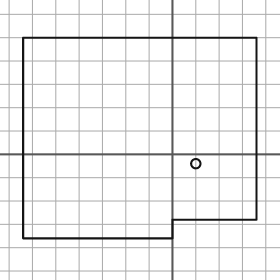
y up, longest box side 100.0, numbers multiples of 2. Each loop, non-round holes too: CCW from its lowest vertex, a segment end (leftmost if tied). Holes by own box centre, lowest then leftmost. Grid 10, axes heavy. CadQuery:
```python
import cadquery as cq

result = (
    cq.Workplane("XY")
    .moveTo(-64.0, -36.0)
    .lineTo(0.0, -36.0)
    .lineTo(0.0, -28.0)
    .lineTo(36.0, -28.0)
    .lineTo(36.0, 50.0)
    .lineTo(-64.0, 50.0)
    .close()
    .moveTo(10.0, -4.0)
    .circle(2.0)
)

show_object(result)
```